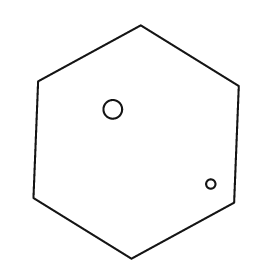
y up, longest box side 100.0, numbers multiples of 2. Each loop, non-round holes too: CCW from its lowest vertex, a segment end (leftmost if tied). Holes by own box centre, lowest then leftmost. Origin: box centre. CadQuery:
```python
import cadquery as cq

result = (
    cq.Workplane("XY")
    .moveTo(-2.0, -50.0)
    .lineTo(42.0, -26.0)
    .lineTo(44.0, 24.0)
    .lineTo(2.0, 50.0)
    .lineTo(-42.0, 26.0)
    .lineTo(-44.0, -24.0)
    .close()
    .moveTo(32.0, -18.0)
    .circle(2.0)
    .moveTo(-10.0, 14.0)
    .circle(4.0)
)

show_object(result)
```